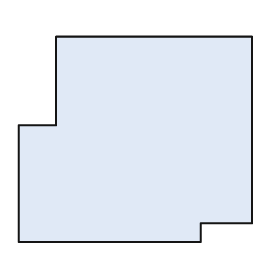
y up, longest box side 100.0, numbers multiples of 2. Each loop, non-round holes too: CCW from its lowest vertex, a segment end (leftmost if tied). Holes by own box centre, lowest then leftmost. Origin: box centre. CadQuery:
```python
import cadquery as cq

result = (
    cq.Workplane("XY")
    .moveTo(-50.0, -44.0)
    .lineTo(28.0, -44.0)
    .lineTo(28.0, -36.0)
    .lineTo(50.0, -36.0)
    .lineTo(50.0, 44.0)
    .lineTo(-34.0, 44.0)
    .lineTo(-34.0, 6.0)
    .lineTo(-50.0, 6.0)
    .close()
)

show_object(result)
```